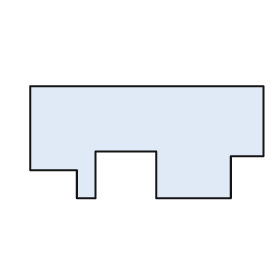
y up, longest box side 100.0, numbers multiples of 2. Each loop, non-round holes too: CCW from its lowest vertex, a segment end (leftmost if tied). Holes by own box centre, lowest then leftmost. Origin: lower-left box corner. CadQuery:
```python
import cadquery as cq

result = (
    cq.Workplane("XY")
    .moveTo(20.0, 0.0)
    .lineTo(28.0, 0.0)
    .lineTo(28.0, 20.0)
    .lineTo(54.0, 20.0)
    .lineTo(54.0, 0.0)
    .lineTo(86.0, 0.0)
    .lineTo(86.0, 18.0)
    .lineTo(100.0, 18.0)
    .lineTo(100.0, 48.0)
    .lineTo(0.0, 48.0)
    .lineTo(0.0, 12.0)
    .lineTo(20.0, 12.0)
    .close()
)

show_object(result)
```